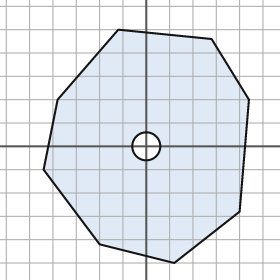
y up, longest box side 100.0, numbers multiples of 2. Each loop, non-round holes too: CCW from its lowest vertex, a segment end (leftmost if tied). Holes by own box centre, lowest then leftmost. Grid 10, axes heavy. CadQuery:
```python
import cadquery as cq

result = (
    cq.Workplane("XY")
    .moveTo(12.0, -50.0)
    .lineTo(40.0, -28.0)
    .lineTo(44.0, 20.0)
    .lineTo(28.0, 46.0)
    .lineTo(-12.0, 50.0)
    .lineTo(-38.0, 20.0)
    .lineTo(-44.0, -10.0)
    .lineTo(-20.0, -42.0)
    .close()
    .moveTo(0.0, 0.0)
    .circle(6.0)
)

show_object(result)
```